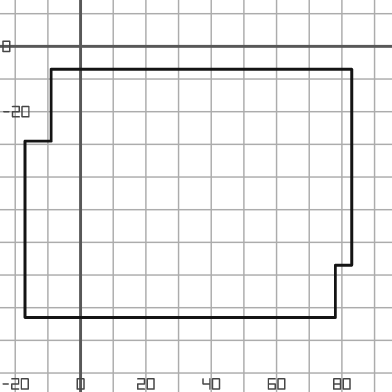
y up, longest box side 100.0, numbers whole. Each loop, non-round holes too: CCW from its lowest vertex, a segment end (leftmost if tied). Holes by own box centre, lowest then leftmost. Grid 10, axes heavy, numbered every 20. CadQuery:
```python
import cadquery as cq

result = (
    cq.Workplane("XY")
    .moveTo(-17.0, -83.0)
    .lineTo(78.0, -83.0)
    .lineTo(78.0, -67.0)
    .lineTo(83.0, -67.0)
    .lineTo(83.0, -7.0)
    .lineTo(-9.0, -7.0)
    .lineTo(-9.0, -29.0)
    .lineTo(-17.0, -29.0)
    .close()
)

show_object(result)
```